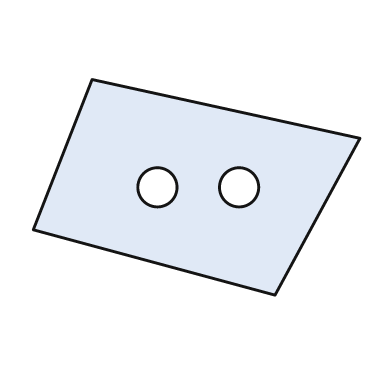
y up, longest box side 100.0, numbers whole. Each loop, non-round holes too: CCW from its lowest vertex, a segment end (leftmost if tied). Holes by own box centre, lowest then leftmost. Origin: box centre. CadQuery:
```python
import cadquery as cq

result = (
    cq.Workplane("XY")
    .moveTo(24.0, -33.0)
    .lineTo(50.0, 15.0)
    .lineTo(-32.0, 33.0)
    .lineTo(-50.0, -13.0)
    .close()
    .moveTo(-12.0, 0.0)
    .circle(6.0)
    .moveTo(13.0, 0.0)
    .circle(6.0)
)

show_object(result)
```